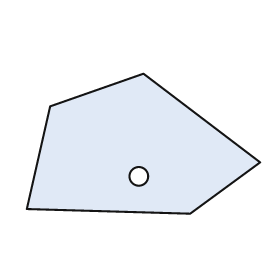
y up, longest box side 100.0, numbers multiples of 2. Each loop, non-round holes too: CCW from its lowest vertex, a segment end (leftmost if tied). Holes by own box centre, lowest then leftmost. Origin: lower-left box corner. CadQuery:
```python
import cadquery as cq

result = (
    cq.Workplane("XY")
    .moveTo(70.0, 0.0)
    .lineTo(100.0, 22.0)
    .lineTo(50.0, 60.0)
    .lineTo(10.0, 46.0)
    .lineTo(0.0, 2.0)
    .close()
    .moveTo(48.0, 16.0)
    .circle(4.0)
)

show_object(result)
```